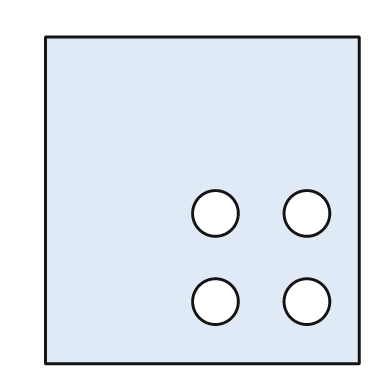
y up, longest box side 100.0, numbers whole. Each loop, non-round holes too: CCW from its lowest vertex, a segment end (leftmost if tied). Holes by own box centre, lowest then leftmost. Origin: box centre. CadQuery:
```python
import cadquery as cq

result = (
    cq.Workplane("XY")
    .moveTo(-48.0, -50.0)
    .lineTo(48.0, -50.0)
    .lineTo(48.0, 50.0)
    .lineTo(-48.0, 50.0)
    .close()
    .moveTo(4.0, -31.0)
    .circle(7.0)
    .moveTo(32.0, -31.0)
    .circle(7.0)
    .moveTo(4.0, -4.0)
    .circle(7.0)
    .moveTo(32.0, -4.0)
    .circle(7.0)
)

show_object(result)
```